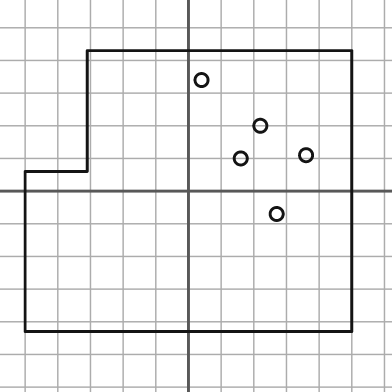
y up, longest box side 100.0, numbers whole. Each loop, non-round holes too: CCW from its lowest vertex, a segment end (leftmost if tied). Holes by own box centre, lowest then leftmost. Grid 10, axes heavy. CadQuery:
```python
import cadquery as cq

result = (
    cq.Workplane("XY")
    .moveTo(-50.0, -43.0)
    .lineTo(50.0, -43.0)
    .lineTo(50.0, 43.0)
    .lineTo(-31.0, 43.0)
    .lineTo(-31.0, 6.0)
    .lineTo(-50.0, 6.0)
    .close()
    .moveTo(27.0, -7.0)
    .circle(2.0)
    .moveTo(16.0, 10.0)
    .circle(2.0)
    .moveTo(36.0, 11.0)
    .circle(2.0)
    .moveTo(22.0, 20.0)
    .circle(2.0)
    .moveTo(4.0, 34.0)
    .circle(2.0)
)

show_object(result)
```